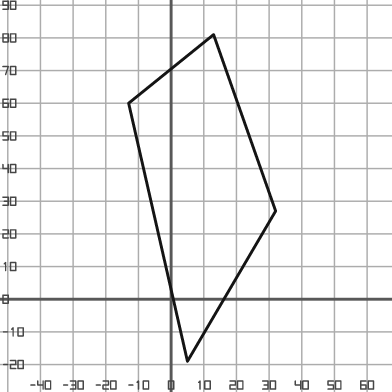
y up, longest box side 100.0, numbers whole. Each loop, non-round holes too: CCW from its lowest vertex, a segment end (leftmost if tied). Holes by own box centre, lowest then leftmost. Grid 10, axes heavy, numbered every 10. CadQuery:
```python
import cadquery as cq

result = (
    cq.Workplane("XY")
    .moveTo(5.0, -19.0)
    .lineTo(32.0, 27.0)
    .lineTo(13.0, 81.0)
    .lineTo(-13.0, 60.0)
    .close()
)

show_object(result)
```